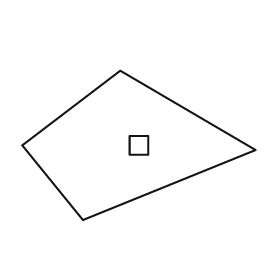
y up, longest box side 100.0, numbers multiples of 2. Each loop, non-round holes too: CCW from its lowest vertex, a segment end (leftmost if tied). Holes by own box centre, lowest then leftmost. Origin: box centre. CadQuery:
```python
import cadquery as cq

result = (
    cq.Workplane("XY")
    .moveTo(-24.0, -32.0)
    .lineTo(50.0, -2.0)
    .lineTo(-8.0, 32.0)
    .lineTo(-50.0, 0.0)
    .close()
    .moveTo(-4.0, -4.0)
    .lineTo(4.0, -4.0)
    .lineTo(4.0, 4.0)
    .lineTo(-4.0, 4.0)
    .close()
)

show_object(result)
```